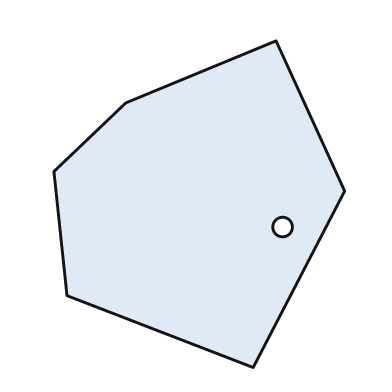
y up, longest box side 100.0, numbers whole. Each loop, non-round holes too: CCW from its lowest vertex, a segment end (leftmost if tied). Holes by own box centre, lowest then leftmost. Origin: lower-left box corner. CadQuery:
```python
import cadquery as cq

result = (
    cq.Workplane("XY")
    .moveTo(61.0, 0.0)
    .lineTo(89.0, 54.0)
    .lineTo(68.0, 100.0)
    .lineTo(22.0, 81.0)
    .lineTo(0.0, 60.0)
    .lineTo(4.0, 22.0)
    .close()
    .moveTo(70.0, 43.0)
    .circle(3.0)
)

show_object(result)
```